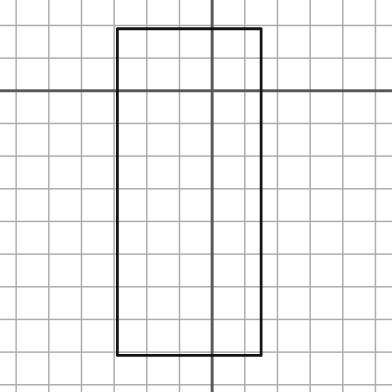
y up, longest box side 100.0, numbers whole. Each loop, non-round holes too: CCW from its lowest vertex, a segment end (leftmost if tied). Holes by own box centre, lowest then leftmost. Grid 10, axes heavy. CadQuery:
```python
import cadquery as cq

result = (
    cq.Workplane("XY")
    .moveTo(-29.0, -81.0)
    .lineTo(15.0, -81.0)
    .lineTo(15.0, 19.0)
    .lineTo(-29.0, 19.0)
    .close()
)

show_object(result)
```